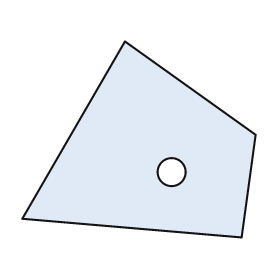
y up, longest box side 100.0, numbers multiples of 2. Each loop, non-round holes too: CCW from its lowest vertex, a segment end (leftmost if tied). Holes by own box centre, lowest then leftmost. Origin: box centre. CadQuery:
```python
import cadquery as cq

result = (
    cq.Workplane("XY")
    .moveTo(44.0, -42.0)
    .lineTo(50.0, 2.0)
    .lineTo(-6.0, 42.0)
    .lineTo(-50.0, -34.0)
    .close()
    .moveTo(14.0, -14.0)
    .circle(6.0)
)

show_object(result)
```